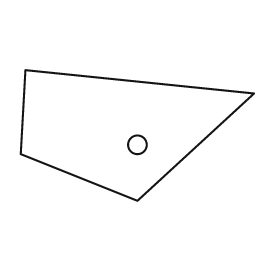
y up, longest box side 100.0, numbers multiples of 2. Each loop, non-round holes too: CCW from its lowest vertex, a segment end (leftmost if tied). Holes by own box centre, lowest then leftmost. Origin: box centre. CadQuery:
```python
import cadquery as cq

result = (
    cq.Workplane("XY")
    .moveTo(0.0, -28.0)
    .lineTo(50.0, 18.0)
    .lineTo(-48.0, 28.0)
    .lineTo(-50.0, -8.0)
    .close()
    .moveTo(0.0, -4.0)
    .circle(4.0)
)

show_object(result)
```